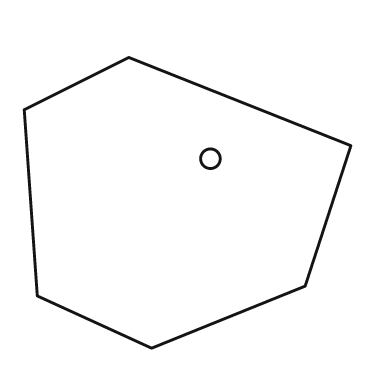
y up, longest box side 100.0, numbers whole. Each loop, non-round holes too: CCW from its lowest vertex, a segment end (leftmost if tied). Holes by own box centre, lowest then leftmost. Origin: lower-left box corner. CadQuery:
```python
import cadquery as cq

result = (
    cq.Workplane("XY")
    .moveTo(39.0, 0.0)
    .lineTo(86.0, 19.0)
    .lineTo(100.0, 62.0)
    .lineTo(32.0, 89.0)
    .lineTo(0.0, 73.0)
    .lineTo(4.0, 16.0)
    .close()
    .moveTo(57.0, 58.0)
    .circle(3.0)
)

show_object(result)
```